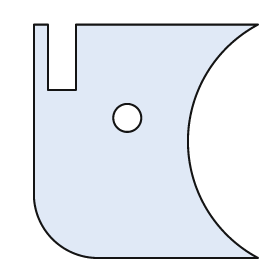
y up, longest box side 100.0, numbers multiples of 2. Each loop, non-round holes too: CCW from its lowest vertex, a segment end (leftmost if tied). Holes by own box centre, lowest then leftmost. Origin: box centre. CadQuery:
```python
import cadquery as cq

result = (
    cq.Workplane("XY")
    .moveTo(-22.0, -50.0)
    .lineTo(48.0, -50.0)
    .threePointArc((18.0, 0.0), (48.0, 50.0))
    .lineTo(-30.0, 50.0)
    .lineTo(-30.0, 22.0)
    .lineTo(-42.0, 22.0)
    .lineTo(-42.0, 50.0)
    .lineTo(-48.0, 50.0)
    .lineTo(-48.0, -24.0)
    .threePointArc((-40.0, -42.0), (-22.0, -50.0))
    .close()
    .moveTo(-8.0, 10.0)
    .circle(6.0)
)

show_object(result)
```